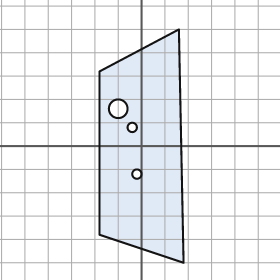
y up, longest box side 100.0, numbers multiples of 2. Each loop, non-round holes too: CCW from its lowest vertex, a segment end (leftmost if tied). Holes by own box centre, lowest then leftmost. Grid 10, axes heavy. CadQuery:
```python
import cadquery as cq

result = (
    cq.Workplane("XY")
    .moveTo(18.0, -50.0)
    .lineTo(16.0, 50.0)
    .lineTo(-18.0, 32.0)
    .lineTo(-18.0, -38.0)
    .close()
    .moveTo(-2.0, -12.0)
    .circle(2.0)
    .moveTo(-4.0, 8.0)
    .circle(2.0)
    .moveTo(-10.0, 16.0)
    .circle(4.0)
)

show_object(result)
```